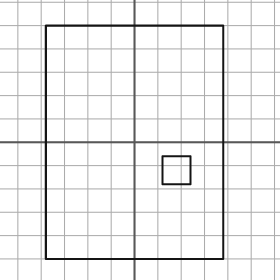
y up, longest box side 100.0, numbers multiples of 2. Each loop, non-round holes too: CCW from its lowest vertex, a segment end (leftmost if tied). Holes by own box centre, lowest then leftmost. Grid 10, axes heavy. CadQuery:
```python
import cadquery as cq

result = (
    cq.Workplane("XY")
    .moveTo(-38.0, -50.0)
    .lineTo(38.0, -50.0)
    .lineTo(38.0, 50.0)
    .lineTo(-38.0, 50.0)
    .close()
    .moveTo(12.0, -18.0)
    .lineTo(24.0, -18.0)
    .lineTo(24.0, -6.0)
    .lineTo(12.0, -6.0)
    .close()
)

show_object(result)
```